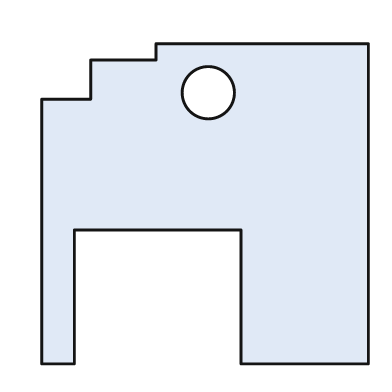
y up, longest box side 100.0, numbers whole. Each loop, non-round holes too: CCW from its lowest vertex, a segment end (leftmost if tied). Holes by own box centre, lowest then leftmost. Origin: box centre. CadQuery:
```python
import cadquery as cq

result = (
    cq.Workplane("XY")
    .moveTo(-50.0, -49.0)
    .lineTo(-40.0, -49.0)
    .lineTo(-40.0, -8.0)
    .lineTo(11.0, -8.0)
    .lineTo(11.0, -49.0)
    .lineTo(50.0, -49.0)
    .lineTo(50.0, 49.0)
    .lineTo(-15.0, 49.0)
    .lineTo(-15.0, 44.0)
    .lineTo(-35.0, 44.0)
    .lineTo(-35.0, 32.0)
    .lineTo(-50.0, 32.0)
    .close()
    .moveTo(1.0, 34.0)
    .circle(8.0)
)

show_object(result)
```